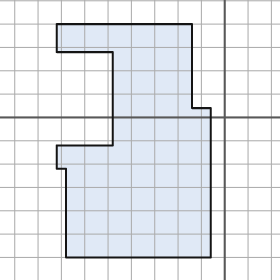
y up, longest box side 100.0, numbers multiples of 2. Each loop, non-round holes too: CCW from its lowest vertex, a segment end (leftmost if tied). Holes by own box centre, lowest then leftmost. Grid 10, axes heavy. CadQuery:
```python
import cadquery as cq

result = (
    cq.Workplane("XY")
    .moveTo(-68.0, -60.0)
    .lineTo(-6.0, -60.0)
    .lineTo(-6.0, 4.0)
    .lineTo(-14.0, 4.0)
    .lineTo(-14.0, 40.0)
    .lineTo(-72.0, 40.0)
    .lineTo(-72.0, 28.0)
    .lineTo(-48.0, 28.0)
    .lineTo(-48.0, -12.0)
    .lineTo(-72.0, -12.0)
    .lineTo(-72.0, -22.0)
    .lineTo(-68.0, -22.0)
    .close()
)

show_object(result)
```